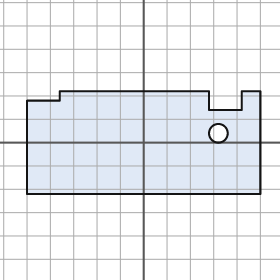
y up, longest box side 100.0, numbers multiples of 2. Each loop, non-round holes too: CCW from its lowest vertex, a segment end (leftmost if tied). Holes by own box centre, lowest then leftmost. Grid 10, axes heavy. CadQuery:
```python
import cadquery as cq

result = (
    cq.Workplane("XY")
    .moveTo(-50.0, -22.0)
    .lineTo(50.0, -22.0)
    .lineTo(50.0, 22.0)
    .lineTo(42.0, 22.0)
    .lineTo(42.0, 14.0)
    .lineTo(28.0, 14.0)
    .lineTo(28.0, 22.0)
    .lineTo(-36.0, 22.0)
    .lineTo(-36.0, 18.0)
    .lineTo(-50.0, 18.0)
    .close()
    .moveTo(32.0, 4.0)
    .circle(4.0)
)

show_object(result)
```